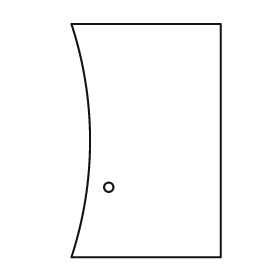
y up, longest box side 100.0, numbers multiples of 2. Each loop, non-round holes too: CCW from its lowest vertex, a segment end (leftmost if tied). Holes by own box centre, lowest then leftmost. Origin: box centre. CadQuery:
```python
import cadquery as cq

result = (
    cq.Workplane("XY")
    .moveTo(-32.0, -50.0)
    .lineTo(32.0, -50.0)
    .lineTo(32.0, 50.0)
    .lineTo(-32.0, 50.0)
    .threePointArc((-24.0, 0.0), (-32.0, -50.0))
    .close()
    .moveTo(-16.0, -20.0)
    .circle(2.0)
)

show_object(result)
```